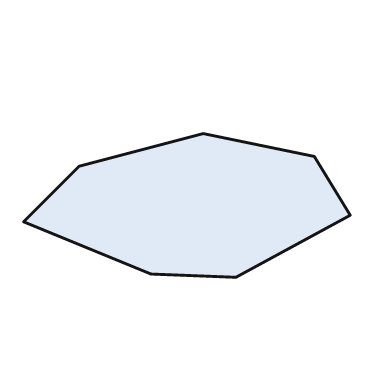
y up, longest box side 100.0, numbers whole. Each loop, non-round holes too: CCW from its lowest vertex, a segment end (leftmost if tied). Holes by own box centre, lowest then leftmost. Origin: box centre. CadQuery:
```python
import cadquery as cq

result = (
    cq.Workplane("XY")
    .moveTo(15.0, -22.0)
    .lineTo(50.0, -3.0)
    .lineTo(39.0, 15.0)
    .lineTo(5.0, 22.0)
    .lineTo(-33.0, 12.0)
    .lineTo(-50.0, -5.0)
    .lineTo(-11.0, -21.0)
    .close()
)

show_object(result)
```